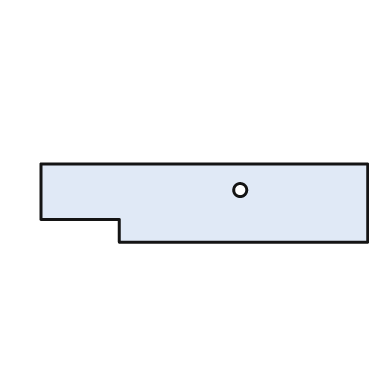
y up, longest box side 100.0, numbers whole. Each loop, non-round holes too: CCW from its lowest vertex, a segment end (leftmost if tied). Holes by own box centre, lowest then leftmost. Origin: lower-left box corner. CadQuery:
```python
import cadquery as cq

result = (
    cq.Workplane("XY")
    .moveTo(24.0, 0.0)
    .lineTo(100.0, 0.0)
    .lineTo(100.0, 24.0)
    .lineTo(0.0, 24.0)
    .lineTo(0.0, 7.0)
    .lineTo(24.0, 7.0)
    .close()
    .moveTo(61.0, 16.0)
    .circle(2.0)
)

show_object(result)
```